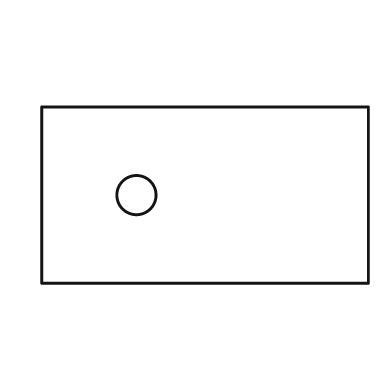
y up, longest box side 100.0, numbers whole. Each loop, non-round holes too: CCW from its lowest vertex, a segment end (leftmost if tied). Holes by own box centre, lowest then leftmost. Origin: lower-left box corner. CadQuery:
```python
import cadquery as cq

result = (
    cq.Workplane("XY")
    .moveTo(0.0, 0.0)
    .lineTo(100.0, 0.0)
    .lineTo(100.0, 54.0)
    .lineTo(0.0, 54.0)
    .close()
    .moveTo(29.0, 27.0)
    .circle(6.0)
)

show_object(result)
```